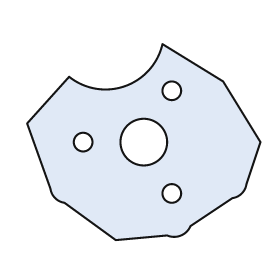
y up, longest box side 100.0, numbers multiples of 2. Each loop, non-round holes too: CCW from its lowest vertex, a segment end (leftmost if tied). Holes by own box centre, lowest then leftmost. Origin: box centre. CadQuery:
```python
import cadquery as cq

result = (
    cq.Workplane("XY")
    .moveTo(-12.0, -42.0)
    .lineTo(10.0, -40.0)
    .threePointArc((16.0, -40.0), (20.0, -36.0))
    .lineTo(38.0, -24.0)
    .threePointArc((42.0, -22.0), (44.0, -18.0))
    .lineTo(50.0, 0.0)
    .lineTo(34.0, 26.0)
    .lineTo(8.0, 42.0)
    .threePointArc((-8.0, 24.0), (-32.0, 28.0))
    .lineTo(-50.0, 8.0)
    .lineTo(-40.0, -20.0)
    .threePointArc((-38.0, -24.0), (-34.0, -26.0))
    .close()
    .moveTo(12.0, -22.0)
    .circle(4.0)
    .moveTo(-26.0, 0.0)
    .circle(4.0)
    .moveTo(0.0, 0.0)
    .circle(10.0)
    .moveTo(12.0, 22.0)
    .circle(4.0)
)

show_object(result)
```